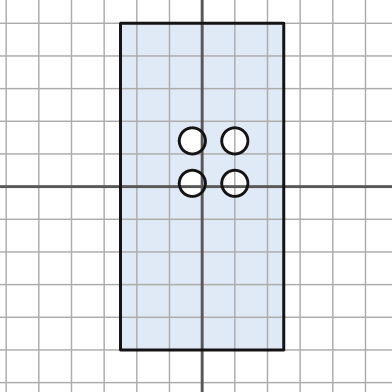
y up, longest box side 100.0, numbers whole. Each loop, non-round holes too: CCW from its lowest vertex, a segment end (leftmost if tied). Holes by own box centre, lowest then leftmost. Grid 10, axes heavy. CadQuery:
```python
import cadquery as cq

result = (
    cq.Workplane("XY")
    .moveTo(-25.0, -50.0)
    .lineTo(25.0, -50.0)
    .lineTo(25.0, 50.0)
    .lineTo(-25.0, 50.0)
    .close()
    .moveTo(-3.0, 1.0)
    .circle(4.0)
    .moveTo(10.0, 1.0)
    .circle(4.0)
    .moveTo(-3.0, 14.0)
    .circle(4.0)
    .moveTo(10.0, 14.0)
    .circle(4.0)
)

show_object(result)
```